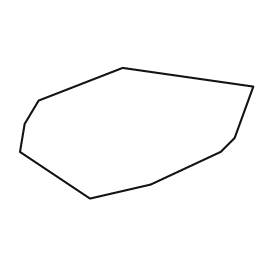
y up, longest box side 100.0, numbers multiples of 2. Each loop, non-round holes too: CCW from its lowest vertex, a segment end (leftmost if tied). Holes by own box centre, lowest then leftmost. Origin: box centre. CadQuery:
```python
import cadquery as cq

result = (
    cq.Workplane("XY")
    .moveTo(-20.0, -28.0)
    .lineTo(6.0, -22.0)
    .lineTo(36.0, -8.0)
    .lineTo(42.0, -2.0)
    .lineTo(50.0, 20.0)
    .lineTo(-6.0, 28.0)
    .lineTo(-42.0, 14.0)
    .lineTo(-48.0, 4.0)
    .lineTo(-50.0, -8.0)
    .close()
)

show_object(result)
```